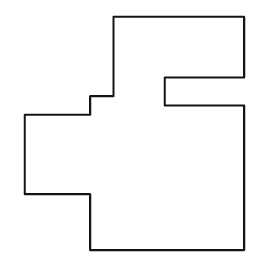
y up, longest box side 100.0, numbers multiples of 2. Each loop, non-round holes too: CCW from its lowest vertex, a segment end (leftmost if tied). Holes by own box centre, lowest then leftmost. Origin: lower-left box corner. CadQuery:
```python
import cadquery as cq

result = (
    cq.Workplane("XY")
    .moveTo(28.0, 0.0)
    .lineTo(94.0, 0.0)
    .lineTo(94.0, 62.0)
    .lineTo(60.0, 62.0)
    .lineTo(60.0, 74.0)
    .lineTo(94.0, 74.0)
    .lineTo(94.0, 100.0)
    .lineTo(38.0, 100.0)
    .lineTo(38.0, 66.0)
    .lineTo(28.0, 66.0)
    .lineTo(28.0, 58.0)
    .lineTo(0.0, 58.0)
    .lineTo(0.0, 24.0)
    .lineTo(28.0, 24.0)
    .close()
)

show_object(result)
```